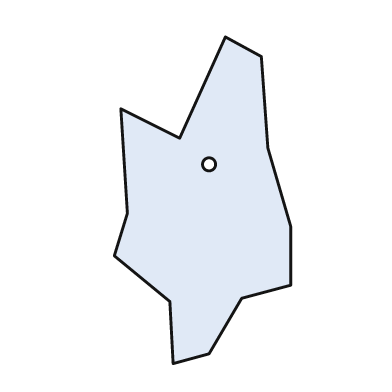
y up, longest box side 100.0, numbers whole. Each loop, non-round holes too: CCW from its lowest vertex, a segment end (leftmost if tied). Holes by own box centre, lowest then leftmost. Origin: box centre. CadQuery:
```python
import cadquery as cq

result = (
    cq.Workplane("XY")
    .moveTo(-9.0, -50.0)
    .lineTo(2.0, -47.0)
    .lineTo(12.0, -30.0)
    .lineTo(27.0, -26.0)
    .lineTo(27.0, -8.0)
    .lineTo(20.0, 16.0)
    .lineTo(18.0, 44.0)
    .lineTo(7.0, 50.0)
    .lineTo(-7.0, 19.0)
    .lineTo(-25.0, 28.0)
    .lineTo(-23.0, -4.0)
    .lineTo(-27.0, -17.0)
    .lineTo(-10.0, -31.0)
    .close()
    .moveTo(2.0, 11.0)
    .circle(2.0)
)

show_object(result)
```